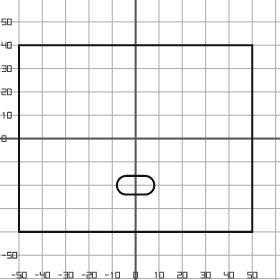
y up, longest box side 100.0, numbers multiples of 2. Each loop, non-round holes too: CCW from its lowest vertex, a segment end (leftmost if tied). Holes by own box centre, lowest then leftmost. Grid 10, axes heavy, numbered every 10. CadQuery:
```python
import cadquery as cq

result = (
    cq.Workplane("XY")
    .moveTo(-50.0, -40.0)
    .lineTo(50.0, -40.0)
    .lineTo(50.0, 40.0)
    .lineTo(-50.0, 40.0)
    .close()
    .moveTo(-4.0, -24.0)
    .lineTo(4.0, -24.0)
    .threePointArc((8.0, -20.0), (4.0, -16.0))
    .lineTo(-4.0, -16.0)
    .threePointArc((-8.0, -20.0), (-4.0, -24.0))
    .close()
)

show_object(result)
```